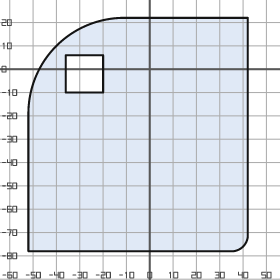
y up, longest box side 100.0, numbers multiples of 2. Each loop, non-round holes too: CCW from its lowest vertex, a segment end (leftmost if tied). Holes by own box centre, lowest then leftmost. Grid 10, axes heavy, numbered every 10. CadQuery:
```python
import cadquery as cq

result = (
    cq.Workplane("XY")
    .moveTo(-52.0, -78.0)
    .lineTo(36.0, -78.0)
    .threePointArc((40.0, -76.0), (42.0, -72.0))
    .lineTo(42.0, 22.0)
    .lineTo(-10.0, 22.0)
    .threePointArc((-40.0, 10.0), (-52.0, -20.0))
    .close()
    .moveTo(-36.0, -10.0)
    .lineTo(-20.0, -10.0)
    .lineTo(-20.0, 6.0)
    .lineTo(-36.0, 6.0)
    .close()
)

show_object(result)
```